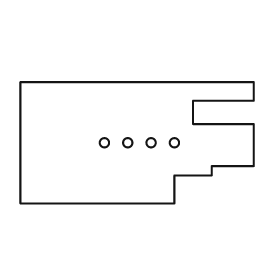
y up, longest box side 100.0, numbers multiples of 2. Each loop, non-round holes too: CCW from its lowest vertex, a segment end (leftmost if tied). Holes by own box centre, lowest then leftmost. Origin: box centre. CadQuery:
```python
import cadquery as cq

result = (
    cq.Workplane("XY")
    .moveTo(-50.0, -26.0)
    .lineTo(16.0, -26.0)
    .lineTo(16.0, -14.0)
    .lineTo(32.0, -14.0)
    .lineTo(32.0, -10.0)
    .lineTo(50.0, -10.0)
    .lineTo(50.0, 8.0)
    .lineTo(24.0, 8.0)
    .lineTo(24.0, 18.0)
    .lineTo(50.0, 18.0)
    .lineTo(50.0, 26.0)
    .lineTo(-50.0, 26.0)
    .close()
    .moveTo(-14.0, 0.0)
    .circle(2.0)
    .moveTo(-4.0, 0.0)
    .circle(2.0)
    .moveTo(6.0, 0.0)
    .circle(2.0)
    .moveTo(16.0, 0.0)
    .circle(2.0)
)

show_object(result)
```